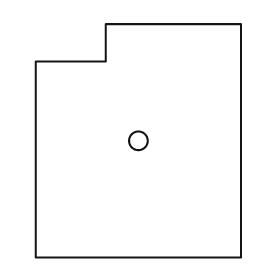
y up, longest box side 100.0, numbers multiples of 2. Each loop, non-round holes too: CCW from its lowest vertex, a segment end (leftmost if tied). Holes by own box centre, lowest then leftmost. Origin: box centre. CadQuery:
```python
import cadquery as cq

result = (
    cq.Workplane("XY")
    .moveTo(-44.0, -50.0)
    .lineTo(44.0, -50.0)
    .lineTo(44.0, 50.0)
    .lineTo(-14.0, 50.0)
    .lineTo(-14.0, 34.0)
    .lineTo(-44.0, 34.0)
    .close()
    .moveTo(0.0, 0.0)
    .circle(4.0)
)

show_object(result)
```